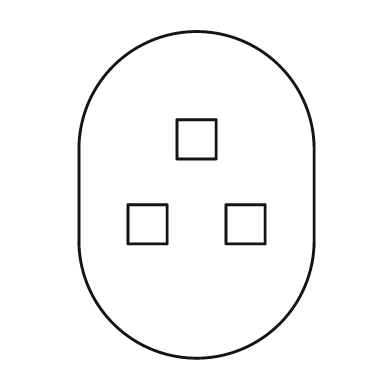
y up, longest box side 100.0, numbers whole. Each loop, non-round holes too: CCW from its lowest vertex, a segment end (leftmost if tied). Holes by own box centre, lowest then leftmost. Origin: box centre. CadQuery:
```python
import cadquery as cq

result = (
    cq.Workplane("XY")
    .moveTo(-36.0, -14.0)
    .threePointArc((0.0, -50.0), (36.0, -14.0))
    .lineTo(36.0, 14.0)
    .threePointArc((0.0, 50.0), (-36.0, 14.0))
    .close()
    .moveTo(-21.0, -15.0)
    .lineTo(-9.0, -15.0)
    .lineTo(-9.0, -3.0)
    .lineTo(-21.0, -3.0)
    .close()
    .moveTo(9.0, -15.0)
    .lineTo(21.0, -15.0)
    .lineTo(21.0, -3.0)
    .lineTo(9.0, -3.0)
    .close()
    .moveTo(-6.0, 11.0)
    .lineTo(6.0, 11.0)
    .lineTo(6.0, 23.0)
    .lineTo(-6.0, 23.0)
    .close()
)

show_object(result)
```